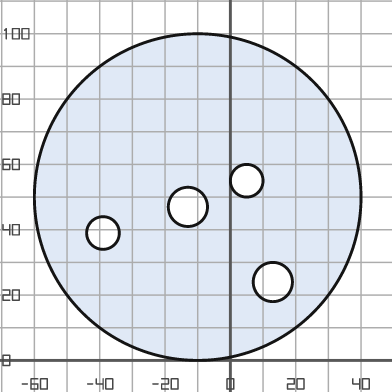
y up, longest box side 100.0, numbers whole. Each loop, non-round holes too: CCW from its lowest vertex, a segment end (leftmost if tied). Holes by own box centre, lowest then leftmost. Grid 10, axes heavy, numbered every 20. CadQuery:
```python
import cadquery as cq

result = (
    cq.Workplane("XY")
    .moveTo(-10.0, 50.0)
    .circle(50.0)
    .moveTo(13.0, 24.0)
    .circle(6.0)
    .moveTo(-39.0, 39.0)
    .circle(5.0)
    .moveTo(-13.0, 47.0)
    .circle(6.0)
    .moveTo(5.0, 55.0)
    .circle(5.0)
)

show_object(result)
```